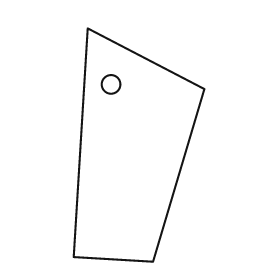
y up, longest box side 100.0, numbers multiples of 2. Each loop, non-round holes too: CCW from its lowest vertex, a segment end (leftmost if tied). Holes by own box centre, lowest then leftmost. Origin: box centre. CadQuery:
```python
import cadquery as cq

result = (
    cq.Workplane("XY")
    .moveTo(6.0, -50.0)
    .lineTo(28.0, 24.0)
    .lineTo(-22.0, 50.0)
    .lineTo(-28.0, -48.0)
    .close()
    .moveTo(-12.0, 26.0)
    .circle(4.0)
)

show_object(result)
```